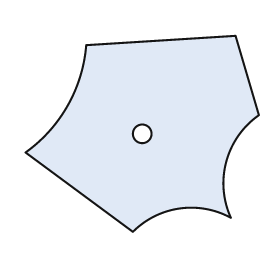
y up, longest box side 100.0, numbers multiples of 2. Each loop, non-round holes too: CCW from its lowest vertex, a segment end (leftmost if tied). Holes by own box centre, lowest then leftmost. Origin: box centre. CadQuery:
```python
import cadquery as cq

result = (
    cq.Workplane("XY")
    .moveTo(-4.0, -42.0)
    .threePointArc((16.0, -32.0), (38.0, -36.0))
    .threePointArc((36.0, -12.0), (50.0, 8.0))
    .lineTo(40.0, 42.0)
    .lineTo(-24.0, 38.0)
    .threePointArc((-32.0, 12.0), (-50.0, -8.0))
    .close()
    .moveTo(0.0, 0.0)
    .circle(4.0)
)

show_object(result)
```